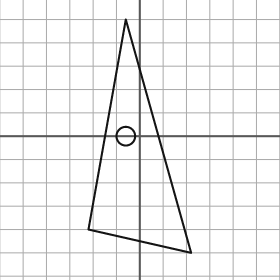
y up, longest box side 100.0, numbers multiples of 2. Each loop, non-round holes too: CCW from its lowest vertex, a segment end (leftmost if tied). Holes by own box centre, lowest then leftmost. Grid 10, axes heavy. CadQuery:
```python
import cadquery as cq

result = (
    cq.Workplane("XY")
    .moveTo(22.0, -50.0)
    .lineTo(-6.0, 50.0)
    .lineTo(-22.0, -40.0)
    .close()
    .moveTo(-6.0, 0.0)
    .circle(4.0)
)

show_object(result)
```